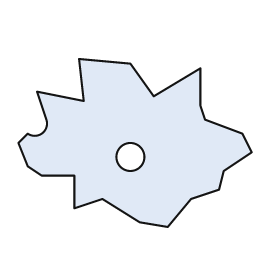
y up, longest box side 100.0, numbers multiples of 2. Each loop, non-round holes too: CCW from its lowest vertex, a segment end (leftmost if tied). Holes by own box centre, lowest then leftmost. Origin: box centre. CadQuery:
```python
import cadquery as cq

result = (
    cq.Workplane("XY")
    .moveTo(14.0, -36.0)
    .lineTo(24.0, -24.0)
    .lineTo(36.0, -20.0)
    .lineTo(38.0, -12.0)
    .lineTo(50.0, -4.0)
    .lineTo(46.0, 4.0)
    .lineTo(30.0, 10.0)
    .lineTo(28.0, 16.0)
    .lineTo(28.0, 32.0)
    .lineTo(8.0, 20.0)
    .lineTo(-2.0, 34.0)
    .lineTo(-24.0, 36.0)
    .lineTo(-22.0, 18.0)
    .lineTo(-42.0, 22.0)
    .lineTo(-38.0, 10.0)
    .threePointArc((-40.0, 4.0), (-46.0, 4.0))
    .lineTo(-50.0, 0.0)
    .lineTo(-46.0, -10.0)
    .lineTo(-40.0, -14.0)
    .lineTo(-26.0, -14.0)
    .lineTo(-26.0, -28.0)
    .lineTo(-14.0, -24.0)
    .lineTo(2.0, -34.0)
    .close()
    .moveTo(-2.0, -6.0)
    .circle(6.0)
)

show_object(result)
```